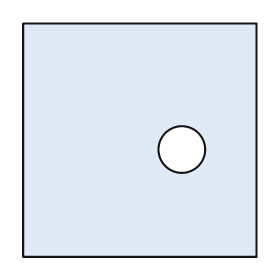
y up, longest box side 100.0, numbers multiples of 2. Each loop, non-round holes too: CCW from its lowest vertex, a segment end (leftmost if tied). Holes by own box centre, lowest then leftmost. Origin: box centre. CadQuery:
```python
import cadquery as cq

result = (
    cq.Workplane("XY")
    .moveTo(-50.0, -50.0)
    .lineTo(50.0, -50.0)
    .lineTo(50.0, 50.0)
    .lineTo(-50.0, 50.0)
    .close()
    .moveTo(18.0, -4.0)
    .circle(10.0)
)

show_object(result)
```